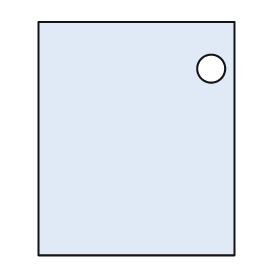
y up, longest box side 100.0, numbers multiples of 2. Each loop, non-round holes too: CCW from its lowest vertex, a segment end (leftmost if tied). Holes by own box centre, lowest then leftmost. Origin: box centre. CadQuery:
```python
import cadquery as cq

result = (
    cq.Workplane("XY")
    .moveTo(-42.0, -50.0)
    .lineTo(42.0, -50.0)
    .lineTo(42.0, 50.0)
    .lineTo(-42.0, 50.0)
    .close()
    .moveTo(32.0, 30.0)
    .circle(6.0)
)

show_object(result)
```